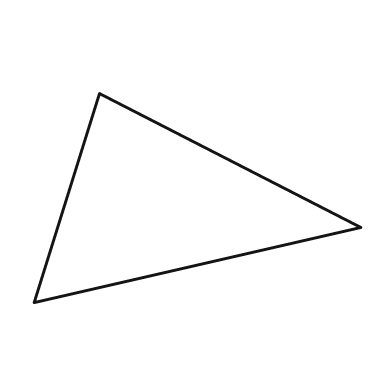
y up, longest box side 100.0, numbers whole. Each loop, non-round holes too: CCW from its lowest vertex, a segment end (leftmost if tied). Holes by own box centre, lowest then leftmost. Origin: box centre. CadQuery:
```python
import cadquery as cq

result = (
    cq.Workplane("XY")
    .moveTo(-50.0, -32.0)
    .lineTo(50.0, -9.0)
    .lineTo(-30.0, 32.0)
    .close()
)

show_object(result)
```